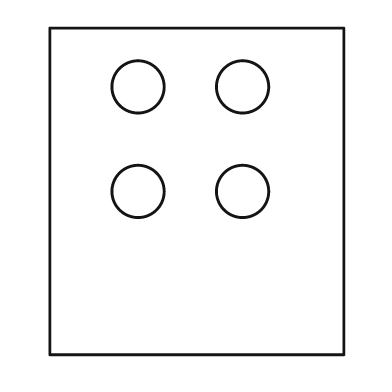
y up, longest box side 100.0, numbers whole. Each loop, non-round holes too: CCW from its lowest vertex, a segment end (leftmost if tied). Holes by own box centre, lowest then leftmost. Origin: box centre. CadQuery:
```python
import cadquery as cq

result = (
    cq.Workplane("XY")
    .moveTo(-45.0, -50.0)
    .lineTo(45.0, -50.0)
    .lineTo(45.0, 50.0)
    .lineTo(-45.0, 50.0)
    .close()
    .moveTo(-18.0, 0.0)
    .circle(8.0)
    .moveTo(14.0, 0.0)
    .circle(8.0)
    .moveTo(-18.0, 32.0)
    .circle(8.0)
    .moveTo(14.0, 32.0)
    .circle(8.0)
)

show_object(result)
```